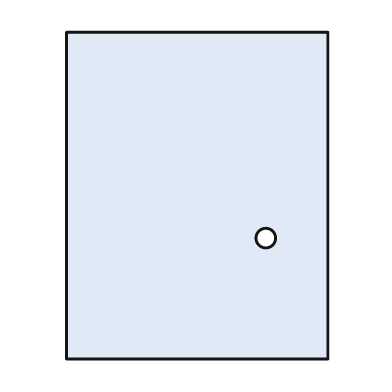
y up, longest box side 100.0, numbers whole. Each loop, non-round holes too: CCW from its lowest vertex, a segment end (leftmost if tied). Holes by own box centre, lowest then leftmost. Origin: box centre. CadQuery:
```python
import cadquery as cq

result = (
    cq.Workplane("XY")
    .moveTo(-40.0, -50.0)
    .lineTo(40.0, -50.0)
    .lineTo(40.0, 50.0)
    .lineTo(-40.0, 50.0)
    .close()
    .moveTo(21.0, -13.0)
    .circle(3.0)
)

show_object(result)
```